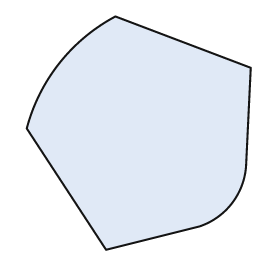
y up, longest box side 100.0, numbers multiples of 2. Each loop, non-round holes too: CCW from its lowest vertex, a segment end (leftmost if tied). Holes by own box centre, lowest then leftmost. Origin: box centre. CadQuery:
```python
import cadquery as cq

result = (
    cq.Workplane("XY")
    .moveTo(-14.0, -50.0)
    .lineTo(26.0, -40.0)
    .threePointArc((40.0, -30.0), (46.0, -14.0))
    .lineTo(48.0, 28.0)
    .lineTo(-10.0, 50.0)
    .threePointArc((-34.0, 30.0), (-48.0, 2.0))
    .close()
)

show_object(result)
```